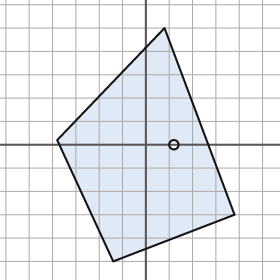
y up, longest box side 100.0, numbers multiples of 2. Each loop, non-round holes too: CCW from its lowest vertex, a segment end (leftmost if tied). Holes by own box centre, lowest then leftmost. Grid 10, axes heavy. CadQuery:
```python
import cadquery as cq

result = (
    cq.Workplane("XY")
    .moveTo(-14.0, -50.0)
    .lineTo(38.0, -30.0)
    .lineTo(8.0, 50.0)
    .lineTo(-38.0, 2.0)
    .close()
    .moveTo(12.0, 0.0)
    .circle(2.0)
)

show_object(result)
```